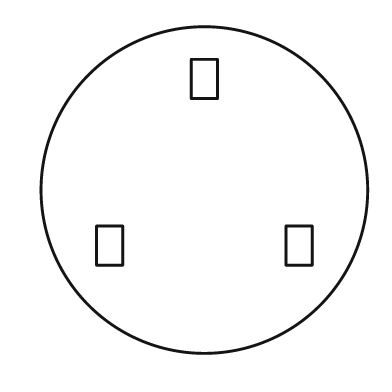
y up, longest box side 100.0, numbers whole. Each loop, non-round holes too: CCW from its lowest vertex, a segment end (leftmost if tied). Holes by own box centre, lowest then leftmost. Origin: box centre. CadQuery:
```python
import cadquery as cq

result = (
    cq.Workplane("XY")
    .moveTo(0.0, 0.0)
    .circle(50.0)
    .moveTo(-33.0, -23.0)
    .lineTo(-25.0, -23.0)
    .lineTo(-25.0, -11.0)
    .lineTo(-33.0, -11.0)
    .close()
    .moveTo(25.0, -23.0)
    .lineTo(33.0, -23.0)
    .lineTo(33.0, -11.0)
    .lineTo(25.0, -11.0)
    .close()
    .moveTo(-4.0, 28.0)
    .lineTo(4.0, 28.0)
    .lineTo(4.0, 40.0)
    .lineTo(-4.0, 40.0)
    .close()
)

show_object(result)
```